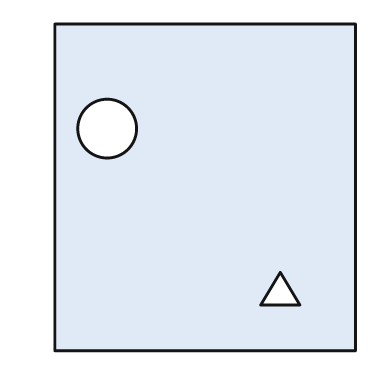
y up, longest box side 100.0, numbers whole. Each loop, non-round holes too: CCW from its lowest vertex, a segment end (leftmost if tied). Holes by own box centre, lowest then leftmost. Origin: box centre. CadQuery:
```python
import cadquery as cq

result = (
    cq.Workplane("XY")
    .moveTo(-46.0, -50.0)
    .lineTo(46.0, -50.0)
    .lineTo(46.0, 50.0)
    .lineTo(-46.0, 50.0)
    .close()
    .moveTo(17.0, -36.0)
    .lineTo(29.0, -36.0)
    .lineTo(23.0, -26.0)
    .close()
    .moveTo(-30.0, 18.0)
    .circle(9.0)
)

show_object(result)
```